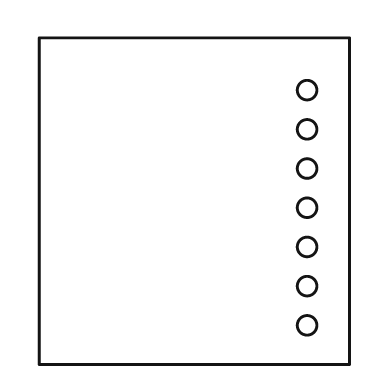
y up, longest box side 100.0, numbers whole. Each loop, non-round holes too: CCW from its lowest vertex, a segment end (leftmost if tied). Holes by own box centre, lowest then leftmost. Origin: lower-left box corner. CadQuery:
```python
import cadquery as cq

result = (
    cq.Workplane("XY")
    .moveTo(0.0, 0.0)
    .lineTo(95.0, 0.0)
    .lineTo(95.0, 100.0)
    .lineTo(0.0, 100.0)
    .close()
    .moveTo(82.0, 12.0)
    .circle(3.0)
    .moveTo(82.0, 24.0)
    .circle(3.0)
    .moveTo(82.0, 36.0)
    .circle(3.0)
    .moveTo(82.0, 48.0)
    .circle(3.0)
    .moveTo(82.0, 60.0)
    .circle(3.0)
    .moveTo(82.0, 72.0)
    .circle(3.0)
    .moveTo(82.0, 84.0)
    .circle(3.0)
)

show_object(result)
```